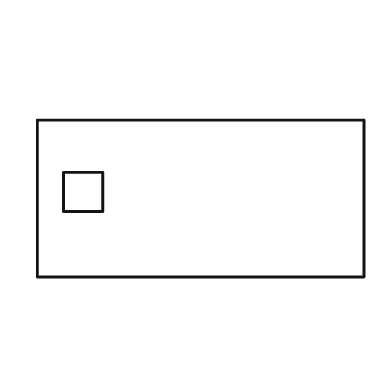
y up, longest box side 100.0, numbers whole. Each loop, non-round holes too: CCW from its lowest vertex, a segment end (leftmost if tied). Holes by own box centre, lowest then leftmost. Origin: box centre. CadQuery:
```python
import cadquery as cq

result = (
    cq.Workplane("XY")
    .moveTo(-50.0, -24.0)
    .lineTo(50.0, -24.0)
    .lineTo(50.0, 24.0)
    .lineTo(-50.0, 24.0)
    .close()
    .moveTo(-42.0, -4.0)
    .lineTo(-30.0, -4.0)
    .lineTo(-30.0, 8.0)
    .lineTo(-42.0, 8.0)
    .close()
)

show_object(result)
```